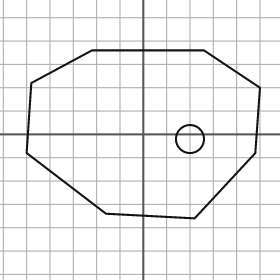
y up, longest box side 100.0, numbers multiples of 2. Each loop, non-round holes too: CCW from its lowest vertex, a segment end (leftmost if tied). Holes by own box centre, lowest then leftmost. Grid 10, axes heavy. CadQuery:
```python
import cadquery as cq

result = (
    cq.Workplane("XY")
    .moveTo(22.0, -36.0)
    .lineTo(48.0, -8.0)
    .lineTo(50.0, 20.0)
    .lineTo(26.0, 36.0)
    .lineTo(-22.0, 36.0)
    .lineTo(-48.0, 22.0)
    .lineTo(-50.0, -8.0)
    .lineTo(-16.0, -34.0)
    .close()
    .moveTo(20.0, -2.0)
    .circle(6.0)
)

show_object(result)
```